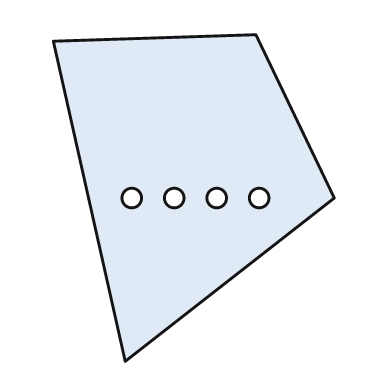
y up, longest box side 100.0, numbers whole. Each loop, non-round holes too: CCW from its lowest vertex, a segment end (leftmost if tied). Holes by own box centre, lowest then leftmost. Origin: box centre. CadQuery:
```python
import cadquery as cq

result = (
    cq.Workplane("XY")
    .moveTo(-21.0, -50.0)
    .lineTo(43.0, 0.0)
    .lineTo(19.0, 50.0)
    .lineTo(-43.0, 48.0)
    .close()
    .moveTo(-19.0, 0.0)
    .circle(3.0)
    .moveTo(-6.0, 0.0)
    .circle(3.0)
    .moveTo(7.0, 0.0)
    .circle(3.0)
    .moveTo(20.0, 0.0)
    .circle(3.0)
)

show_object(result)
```